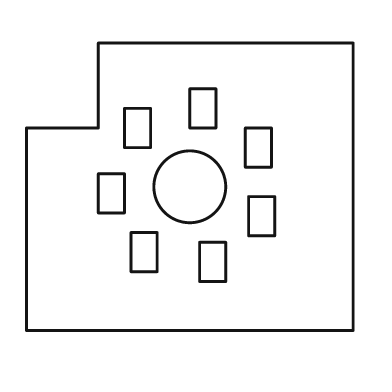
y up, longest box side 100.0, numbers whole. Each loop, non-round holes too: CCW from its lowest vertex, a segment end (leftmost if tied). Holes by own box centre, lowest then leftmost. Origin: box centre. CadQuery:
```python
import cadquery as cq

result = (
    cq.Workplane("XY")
    .moveTo(-50.0, -44.0)
    .lineTo(50.0, -44.0)
    .lineTo(50.0, 44.0)
    .lineTo(-28.0, 44.0)
    .lineTo(-28.0, 18.0)
    .lineTo(-50.0, 18.0)
    .close()
    .moveTo(3.0, -29.0)
    .lineTo(11.0, -29.0)
    .lineTo(11.0, -17.0)
    .lineTo(3.0, -17.0)
    .close()
    .moveTo(-18.0, -26.0)
    .lineTo(-10.0, -26.0)
    .lineTo(-10.0, -14.0)
    .lineTo(-18.0, -14.0)
    .close()
    .moveTo(18.0, -15.0)
    .lineTo(26.0, -15.0)
    .lineTo(26.0, -3.0)
    .lineTo(18.0, -3.0)
    .close()
    .moveTo(-28.0, -8.0)
    .lineTo(-20.0, -8.0)
    .lineTo(-20.0, 4.0)
    .lineTo(-28.0, 4.0)
    .close()
    .moveTo(0.0, 0.0)
    .circle(11.0)
    .moveTo(17.0, 6.0)
    .lineTo(25.0, 6.0)
    .lineTo(25.0, 18.0)
    .lineTo(17.0, 18.0)
    .close()
    .moveTo(-20.0, 12.0)
    .lineTo(-12.0, 12.0)
    .lineTo(-12.0, 24.0)
    .lineTo(-20.0, 24.0)
    .close()
    .moveTo(0.0, 18.0)
    .lineTo(8.0, 18.0)
    .lineTo(8.0, 30.0)
    .lineTo(0.0, 30.0)
    .close()
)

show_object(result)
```